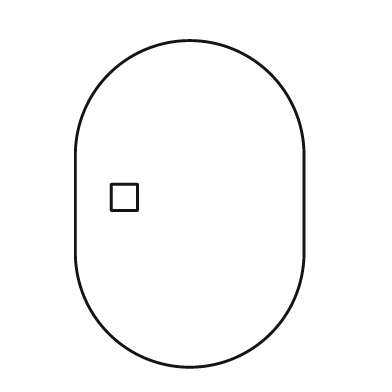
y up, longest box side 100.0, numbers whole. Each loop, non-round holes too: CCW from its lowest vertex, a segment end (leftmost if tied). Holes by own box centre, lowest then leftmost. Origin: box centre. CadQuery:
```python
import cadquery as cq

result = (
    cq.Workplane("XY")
    .moveTo(-35.0, -15.0)
    .threePointArc((0.0, -50.0), (35.0, -15.0))
    .lineTo(35.0, 15.0)
    .threePointArc((0.0, 50.0), (-35.0, 15.0))
    .close()
    .moveTo(-24.0, -2.0)
    .lineTo(-16.0, -2.0)
    .lineTo(-16.0, 6.0)
    .lineTo(-24.0, 6.0)
    .close()
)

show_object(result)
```